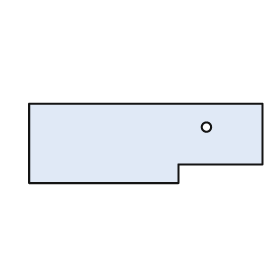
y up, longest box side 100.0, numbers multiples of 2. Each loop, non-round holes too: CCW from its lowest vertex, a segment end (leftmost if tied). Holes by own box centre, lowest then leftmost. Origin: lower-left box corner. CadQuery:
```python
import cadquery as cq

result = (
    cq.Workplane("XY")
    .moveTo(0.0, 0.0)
    .lineTo(64.0, 0.0)
    .lineTo(64.0, 8.0)
    .lineTo(100.0, 8.0)
    .lineTo(100.0, 34.0)
    .lineTo(0.0, 34.0)
    .close()
    .moveTo(76.0, 24.0)
    .circle(2.0)
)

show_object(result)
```